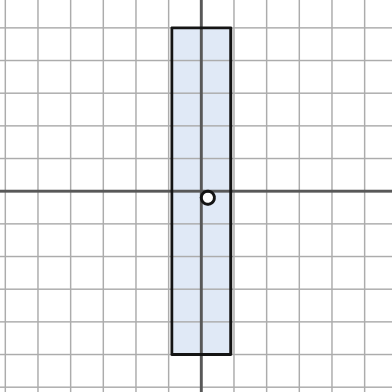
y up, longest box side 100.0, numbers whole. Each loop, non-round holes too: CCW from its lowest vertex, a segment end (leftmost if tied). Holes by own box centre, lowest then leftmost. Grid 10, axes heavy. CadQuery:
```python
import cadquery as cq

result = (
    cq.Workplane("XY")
    .moveTo(-9.0, -50.0)
    .lineTo(9.0, -50.0)
    .lineTo(9.0, 50.0)
    .lineTo(-9.0, 50.0)
    .close()
    .moveTo(2.0, -2.0)
    .circle(2.0)
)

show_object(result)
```